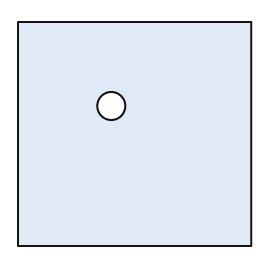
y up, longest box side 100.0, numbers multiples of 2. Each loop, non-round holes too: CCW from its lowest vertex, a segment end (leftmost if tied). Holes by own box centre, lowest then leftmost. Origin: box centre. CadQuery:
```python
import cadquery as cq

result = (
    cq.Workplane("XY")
    .moveTo(-50.0, -48.0)
    .lineTo(50.0, -48.0)
    .lineTo(50.0, 48.0)
    .lineTo(-50.0, 48.0)
    .close()
    .moveTo(-10.0, 12.0)
    .circle(6.0)
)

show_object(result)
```